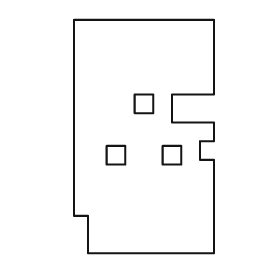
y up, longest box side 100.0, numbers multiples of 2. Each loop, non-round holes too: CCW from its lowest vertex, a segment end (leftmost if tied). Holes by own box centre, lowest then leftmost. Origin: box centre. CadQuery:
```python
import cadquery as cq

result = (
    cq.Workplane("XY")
    .moveTo(-24.0, -50.0)
    .lineTo(30.0, -50.0)
    .lineTo(30.0, -10.0)
    .lineTo(24.0, -10.0)
    .lineTo(24.0, -2.0)
    .lineTo(30.0, -2.0)
    .lineTo(30.0, 6.0)
    .lineTo(12.0, 6.0)
    .lineTo(12.0, 18.0)
    .lineTo(30.0, 18.0)
    .lineTo(30.0, 50.0)
    .lineTo(-30.0, 50.0)
    .lineTo(-30.0, -34.0)
    .lineTo(-24.0, -34.0)
    .close()
    .moveTo(-16.0, -12.0)
    .lineTo(-8.0, -12.0)
    .lineTo(-8.0, -4.0)
    .lineTo(-16.0, -4.0)
    .close()
    .moveTo(8.0, -12.0)
    .lineTo(16.0, -12.0)
    .lineTo(16.0, -4.0)
    .lineTo(8.0, -4.0)
    .close()
    .moveTo(-4.0, 10.0)
    .lineTo(4.0, 10.0)
    .lineTo(4.0, 18.0)
    .lineTo(-4.0, 18.0)
    .close()
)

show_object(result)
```